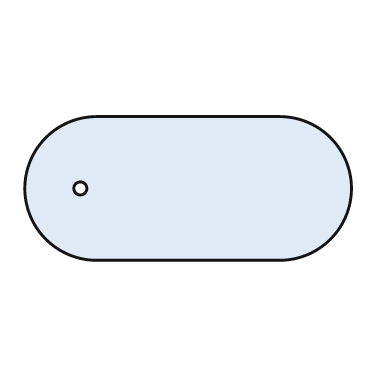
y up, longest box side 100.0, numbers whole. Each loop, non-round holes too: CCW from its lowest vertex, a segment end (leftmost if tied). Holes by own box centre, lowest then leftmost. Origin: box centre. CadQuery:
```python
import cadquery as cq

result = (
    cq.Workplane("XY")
    .moveTo(-28.0, -22.0)
    .lineTo(28.0, -22.0)
    .threePointArc((50.0, 0.0), (28.0, 22.0))
    .lineTo(-28.0, 22.0)
    .threePointArc((-50.0, 0.0), (-28.0, -22.0))
    .close()
    .moveTo(-33.0, 0.0)
    .circle(2.0)
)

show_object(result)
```